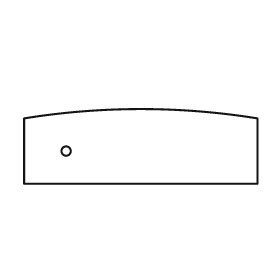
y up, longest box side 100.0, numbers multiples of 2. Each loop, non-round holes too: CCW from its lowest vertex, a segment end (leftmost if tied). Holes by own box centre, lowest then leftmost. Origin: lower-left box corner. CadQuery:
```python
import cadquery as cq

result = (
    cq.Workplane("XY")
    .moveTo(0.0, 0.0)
    .lineTo(100.0, 0.0)
    .lineTo(100.0, 28.0)
    .threePointArc((50.0, 32.0), (0.0, 28.0))
    .close()
    .moveTo(18.0, 14.0)
    .circle(2.0)
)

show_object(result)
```